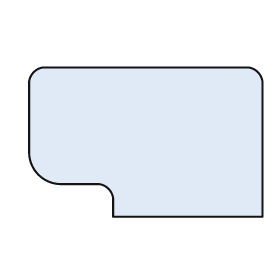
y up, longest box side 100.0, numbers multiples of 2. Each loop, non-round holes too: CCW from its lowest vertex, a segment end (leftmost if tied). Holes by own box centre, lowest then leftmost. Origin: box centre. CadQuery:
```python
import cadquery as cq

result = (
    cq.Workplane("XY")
    .moveTo(-14.0, -32.0)
    .lineTo(50.0, -32.0)
    .lineTo(50.0, 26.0)
    .threePointArc((48.0, 30.0), (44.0, 32.0))
    .lineTo(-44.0, 32.0)
    .threePointArc((-48.0, 30.0), (-50.0, 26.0))
    .lineTo(-50.0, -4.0)
    .threePointArc((-46.0, -14.0), (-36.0, -18.0))
    .lineTo(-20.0, -18.0)
    .threePointArc((-16.0, -20.0), (-14.0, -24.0))
    .close()
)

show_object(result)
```